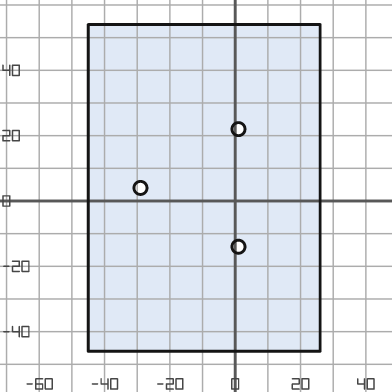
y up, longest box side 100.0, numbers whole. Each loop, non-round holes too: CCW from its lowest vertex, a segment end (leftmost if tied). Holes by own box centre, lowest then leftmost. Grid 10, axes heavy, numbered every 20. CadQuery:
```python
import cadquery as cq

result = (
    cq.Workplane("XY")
    .moveTo(-45.0, -46.0)
    .lineTo(26.0, -46.0)
    .lineTo(26.0, 54.0)
    .lineTo(-45.0, 54.0)
    .close()
    .moveTo(1.0, -14.0)
    .circle(2.0)
    .moveTo(-29.0, 4.0)
    .circle(2.0)
    .moveTo(1.0, 22.0)
    .circle(2.0)
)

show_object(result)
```